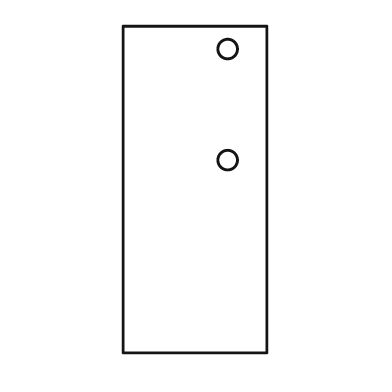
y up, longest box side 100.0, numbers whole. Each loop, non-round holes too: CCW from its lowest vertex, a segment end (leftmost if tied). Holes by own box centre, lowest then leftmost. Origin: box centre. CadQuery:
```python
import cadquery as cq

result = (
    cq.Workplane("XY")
    .moveTo(-22.0, -50.0)
    .lineTo(22.0, -50.0)
    .lineTo(22.0, 50.0)
    .lineTo(-22.0, 50.0)
    .close()
    .moveTo(10.0, 9.0)
    .circle(3.0)
    .moveTo(10.0, 43.0)
    .circle(3.0)
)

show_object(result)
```